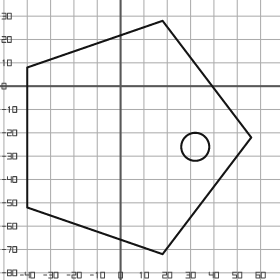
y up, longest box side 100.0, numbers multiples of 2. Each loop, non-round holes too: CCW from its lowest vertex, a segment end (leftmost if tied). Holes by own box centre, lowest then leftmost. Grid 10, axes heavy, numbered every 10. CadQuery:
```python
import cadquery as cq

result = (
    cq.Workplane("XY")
    .moveTo(18.0, -72.0)
    .lineTo(56.0, -22.0)
    .lineTo(18.0, 28.0)
    .lineTo(-40.0, 8.0)
    .lineTo(-40.0, -52.0)
    .close()
    .moveTo(32.0, -26.0)
    .circle(6.0)
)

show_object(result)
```